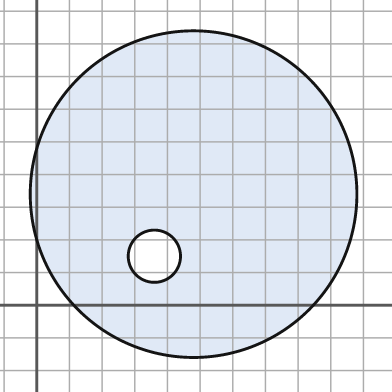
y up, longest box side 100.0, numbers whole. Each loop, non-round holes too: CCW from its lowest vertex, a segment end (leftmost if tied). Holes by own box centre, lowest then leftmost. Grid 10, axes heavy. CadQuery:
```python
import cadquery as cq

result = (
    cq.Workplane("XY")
    .moveTo(48.0, 34.0)
    .circle(50.0)
    .moveTo(36.0, 15.0)
    .circle(8.0)
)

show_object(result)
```